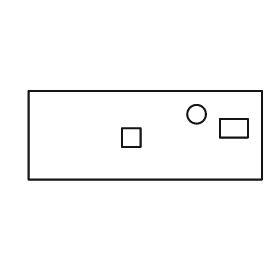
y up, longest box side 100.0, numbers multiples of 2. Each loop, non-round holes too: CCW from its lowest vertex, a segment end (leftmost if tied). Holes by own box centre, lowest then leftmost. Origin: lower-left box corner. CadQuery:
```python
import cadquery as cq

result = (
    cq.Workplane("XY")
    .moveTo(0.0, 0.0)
    .lineTo(100.0, 0.0)
    .lineTo(100.0, 38.0)
    .lineTo(0.0, 38.0)
    .close()
    .moveTo(40.0, 14.0)
    .lineTo(48.0, 14.0)
    .lineTo(48.0, 22.0)
    .lineTo(40.0, 22.0)
    .close()
    .moveTo(82.0, 18.0)
    .lineTo(94.0, 18.0)
    .lineTo(94.0, 26.0)
    .lineTo(82.0, 26.0)
    .close()
    .moveTo(72.0, 28.0)
    .circle(4.0)
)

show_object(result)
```